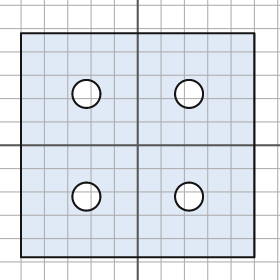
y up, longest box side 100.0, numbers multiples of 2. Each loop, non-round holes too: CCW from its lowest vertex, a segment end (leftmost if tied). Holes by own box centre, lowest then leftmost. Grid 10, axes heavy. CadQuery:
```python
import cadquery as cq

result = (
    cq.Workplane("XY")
    .moveTo(-50.0, -48.0)
    .lineTo(50.0, -48.0)
    .lineTo(50.0, 48.0)
    .lineTo(-50.0, 48.0)
    .close()
    .moveTo(-22.0, -22.0)
    .circle(6.0)
    .moveTo(22.0, -22.0)
    .circle(6.0)
    .moveTo(-22.0, 22.0)
    .circle(6.0)
    .moveTo(22.0, 22.0)
    .circle(6.0)
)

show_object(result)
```